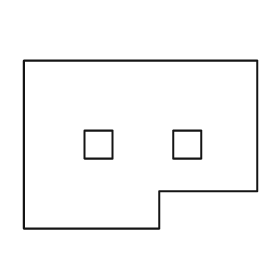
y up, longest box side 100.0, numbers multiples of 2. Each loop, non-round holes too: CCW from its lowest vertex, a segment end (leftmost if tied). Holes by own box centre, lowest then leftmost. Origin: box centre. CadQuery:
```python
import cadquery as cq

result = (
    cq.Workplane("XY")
    .moveTo(-50.0, -36.0)
    .lineTo(8.0, -36.0)
    .lineTo(8.0, -20.0)
    .lineTo(50.0, -20.0)
    .lineTo(50.0, 36.0)
    .lineTo(-50.0, 36.0)
    .close()
    .moveTo(-24.0, -6.0)
    .lineTo(-12.0, -6.0)
    .lineTo(-12.0, 6.0)
    .lineTo(-24.0, 6.0)
    .close()
    .moveTo(14.0, -6.0)
    .lineTo(26.0, -6.0)
    .lineTo(26.0, 6.0)
    .lineTo(14.0, 6.0)
    .close()
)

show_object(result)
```